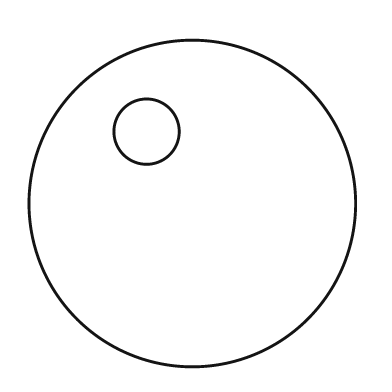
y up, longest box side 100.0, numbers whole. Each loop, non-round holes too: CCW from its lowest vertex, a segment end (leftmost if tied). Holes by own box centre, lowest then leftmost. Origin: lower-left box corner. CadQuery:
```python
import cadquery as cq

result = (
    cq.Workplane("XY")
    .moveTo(50.0, 50.0)
    .circle(50.0)
    .moveTo(36.0, 72.0)
    .circle(10.0)
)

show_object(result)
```